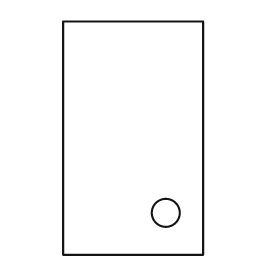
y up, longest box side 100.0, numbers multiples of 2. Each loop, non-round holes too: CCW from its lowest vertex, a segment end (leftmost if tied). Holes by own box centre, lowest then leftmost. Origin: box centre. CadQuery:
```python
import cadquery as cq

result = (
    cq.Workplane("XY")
    .moveTo(-30.0, -50.0)
    .lineTo(30.0, -50.0)
    .lineTo(30.0, 50.0)
    .lineTo(-30.0, 50.0)
    .close()
    .moveTo(14.0, -32.0)
    .circle(6.0)
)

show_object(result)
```